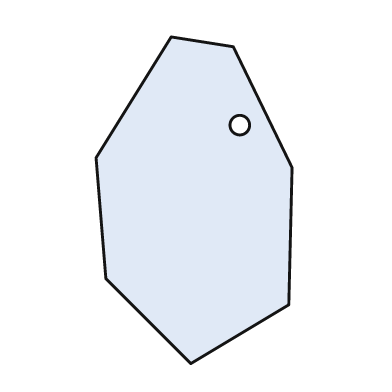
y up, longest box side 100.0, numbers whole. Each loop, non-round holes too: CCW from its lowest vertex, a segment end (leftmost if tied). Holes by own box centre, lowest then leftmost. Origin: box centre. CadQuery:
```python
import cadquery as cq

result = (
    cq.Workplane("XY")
    .moveTo(-1.0, -50.0)
    .lineTo(29.0, -32.0)
    .lineTo(30.0, 10.0)
    .lineTo(12.0, 47.0)
    .lineTo(-7.0, 50.0)
    .lineTo(-30.0, 13.0)
    .lineTo(-27.0, -24.0)
    .close()
    .moveTo(14.0, 23.0)
    .circle(3.0)
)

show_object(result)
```